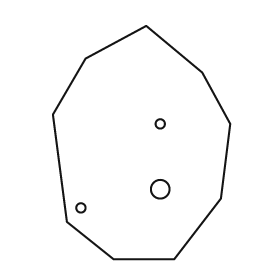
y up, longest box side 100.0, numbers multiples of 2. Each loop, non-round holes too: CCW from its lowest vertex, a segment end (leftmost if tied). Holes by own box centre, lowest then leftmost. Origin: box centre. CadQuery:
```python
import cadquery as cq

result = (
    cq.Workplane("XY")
    .moveTo(-12.0, -50.0)
    .lineTo(14.0, -50.0)
    .lineTo(34.0, -24.0)
    .lineTo(38.0, 8.0)
    .lineTo(26.0, 30.0)
    .lineTo(2.0, 50.0)
    .lineTo(-24.0, 36.0)
    .lineTo(-38.0, 12.0)
    .lineTo(-32.0, -34.0)
    .close()
    .moveTo(-26.0, -28.0)
    .circle(2.0)
    .moveTo(8.0, -20.0)
    .circle(4.0)
    .moveTo(8.0, 8.0)
    .circle(2.0)
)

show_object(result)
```